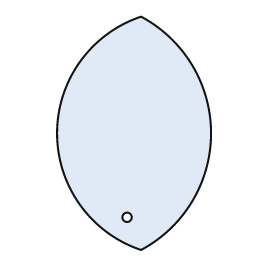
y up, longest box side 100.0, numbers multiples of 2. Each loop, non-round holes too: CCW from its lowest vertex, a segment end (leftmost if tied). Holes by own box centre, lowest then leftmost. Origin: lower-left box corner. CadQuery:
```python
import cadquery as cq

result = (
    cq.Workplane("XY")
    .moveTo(36.0, 0.0)
    .threePointArc((66.0, 50.0), (36.0, 100.0))
    .threePointArc((0.0, 50.0), (36.0, 0.0))
    .close()
    .moveTo(30.0, 14.0)
    .circle(2.0)
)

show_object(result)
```